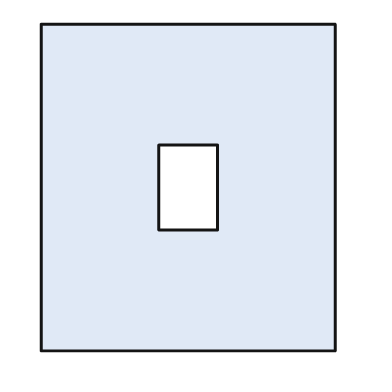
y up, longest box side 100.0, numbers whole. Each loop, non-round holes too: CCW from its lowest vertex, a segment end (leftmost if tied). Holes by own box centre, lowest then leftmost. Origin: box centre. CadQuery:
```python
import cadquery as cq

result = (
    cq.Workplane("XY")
    .moveTo(-45.0, -50.0)
    .lineTo(45.0, -50.0)
    .lineTo(45.0, 50.0)
    .lineTo(-45.0, 50.0)
    .close()
    .moveTo(-9.0, -13.0)
    .lineTo(9.0, -13.0)
    .lineTo(9.0, 13.0)
    .lineTo(-9.0, 13.0)
    .close()
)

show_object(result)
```